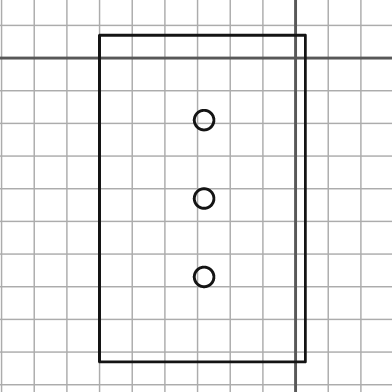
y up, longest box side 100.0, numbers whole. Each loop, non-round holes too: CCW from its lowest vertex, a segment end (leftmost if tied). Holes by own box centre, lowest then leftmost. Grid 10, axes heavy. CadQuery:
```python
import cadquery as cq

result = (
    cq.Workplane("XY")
    .moveTo(-60.0, -93.0)
    .lineTo(3.0, -93.0)
    .lineTo(3.0, 7.0)
    .lineTo(-60.0, 7.0)
    .close()
    .moveTo(-28.0, -67.0)
    .circle(3.0)
    .moveTo(-28.0, -43.0)
    .circle(3.0)
    .moveTo(-28.0, -19.0)
    .circle(3.0)
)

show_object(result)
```